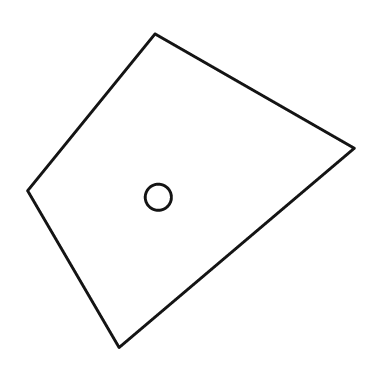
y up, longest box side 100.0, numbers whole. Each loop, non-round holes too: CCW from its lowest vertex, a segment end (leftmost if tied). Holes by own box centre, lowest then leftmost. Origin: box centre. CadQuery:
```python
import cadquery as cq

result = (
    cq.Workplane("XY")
    .moveTo(-22.0, -48.0)
    .lineTo(50.0, 13.0)
    .lineTo(-11.0, 48.0)
    .lineTo(-50.0, 0.0)
    .close()
    .moveTo(-10.0, -2.0)
    .circle(4.0)
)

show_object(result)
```